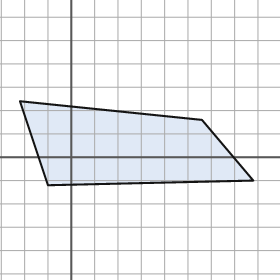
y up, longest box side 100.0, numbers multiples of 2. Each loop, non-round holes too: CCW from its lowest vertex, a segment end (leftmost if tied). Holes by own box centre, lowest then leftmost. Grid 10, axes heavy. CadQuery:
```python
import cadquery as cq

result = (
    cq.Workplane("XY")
    .moveTo(-10.0, -12.0)
    .lineTo(78.0, -10.0)
    .lineTo(56.0, 16.0)
    .lineTo(-22.0, 24.0)
    .close()
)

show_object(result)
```